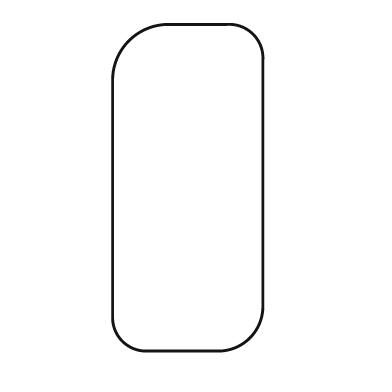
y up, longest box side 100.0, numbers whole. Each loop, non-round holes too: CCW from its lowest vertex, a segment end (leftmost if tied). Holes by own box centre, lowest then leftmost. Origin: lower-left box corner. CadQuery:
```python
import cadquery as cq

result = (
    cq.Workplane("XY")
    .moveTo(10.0, 0.0)
    .lineTo(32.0, 0.0)
    .threePointArc((42.0, 4.0), (46.0, 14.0))
    .lineTo(46.0, 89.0)
    .threePointArc((43.0, 97.0), (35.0, 100.0))
    .lineTo(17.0, 100.0)
    .threePointArc((5.0, 95.0), (0.0, 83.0))
    .lineTo(0.0, 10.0)
    .threePointArc((3.0, 3.0), (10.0, 0.0))
    .close()
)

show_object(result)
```